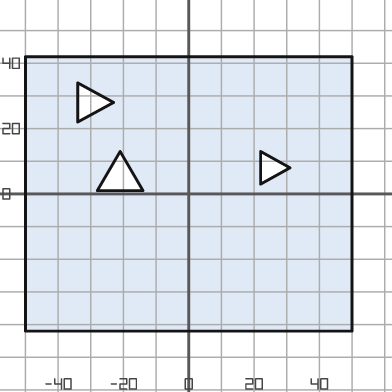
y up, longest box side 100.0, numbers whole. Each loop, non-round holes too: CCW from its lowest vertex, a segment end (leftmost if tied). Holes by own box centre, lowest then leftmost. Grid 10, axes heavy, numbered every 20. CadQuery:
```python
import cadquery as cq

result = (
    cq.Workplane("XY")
    .moveTo(-50.0, -42.0)
    .lineTo(50.0, -42.0)
    .lineTo(50.0, 42.0)
    .lineTo(-50.0, 42.0)
    .close()
    .moveTo(-28.0, 1.0)
    .lineTo(-14.0, 1.0)
    .lineTo(-21.0, 13.0)
    .close()
    .moveTo(22.0, 3.0)
    .lineTo(31.0, 8.0)
    .lineTo(22.0, 13.0)
    .close()
    .moveTo(-34.0, 22.0)
    .lineTo(-23.0, 28.0)
    .lineTo(-34.0, 34.0)
    .close()
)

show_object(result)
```